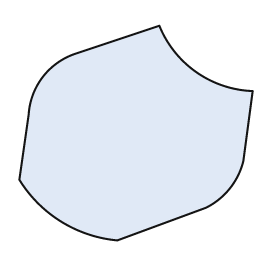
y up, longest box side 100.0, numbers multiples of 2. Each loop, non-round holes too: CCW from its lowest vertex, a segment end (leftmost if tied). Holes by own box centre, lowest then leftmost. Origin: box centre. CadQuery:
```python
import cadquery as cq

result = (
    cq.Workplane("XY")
    .moveTo(-8.0, -46.0)
    .lineTo(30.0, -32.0)
    .threePointArc((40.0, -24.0), (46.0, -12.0))
    .lineTo(50.0, 18.0)
    .threePointArc((26.0, 26.0), (10.0, 46.0))
    .lineTo(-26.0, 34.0)
    .threePointArc((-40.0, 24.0), (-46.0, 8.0))
    .lineTo(-50.0, -20.0)
    .threePointArc((-32.0, -38.0), (-8.0, -46.0))
    .close()
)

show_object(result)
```